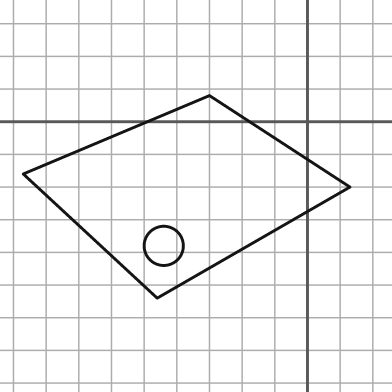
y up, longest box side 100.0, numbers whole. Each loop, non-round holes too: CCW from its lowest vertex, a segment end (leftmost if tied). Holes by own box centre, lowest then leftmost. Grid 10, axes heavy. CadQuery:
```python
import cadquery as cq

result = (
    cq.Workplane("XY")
    .moveTo(-46.0, -54.0)
    .lineTo(13.0, -20.0)
    .lineTo(-30.0, 8.0)
    .lineTo(-87.0, -16.0)
    .close()
    .moveTo(-44.0, -38.0)
    .circle(6.0)
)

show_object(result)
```